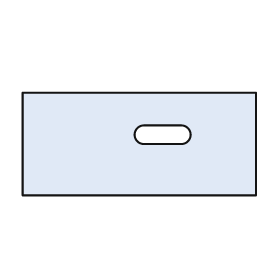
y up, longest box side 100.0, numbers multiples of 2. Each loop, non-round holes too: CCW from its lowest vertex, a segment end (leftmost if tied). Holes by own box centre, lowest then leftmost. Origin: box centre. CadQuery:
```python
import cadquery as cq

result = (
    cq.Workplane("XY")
    .moveTo(-50.0, -22.0)
    .lineTo(50.0, -22.0)
    .lineTo(50.0, 22.0)
    .lineTo(-50.0, 22.0)
    .close()
    .moveTo(2.0, 0.0)
    .lineTo(18.0, 0.0)
    .threePointArc((22.0, 4.0), (18.0, 8.0))
    .lineTo(2.0, 8.0)
    .threePointArc((-2.0, 4.0), (2.0, 0.0))
    .close()
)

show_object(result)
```